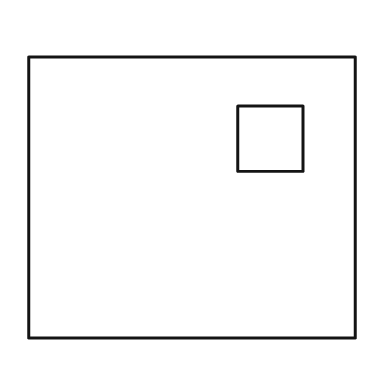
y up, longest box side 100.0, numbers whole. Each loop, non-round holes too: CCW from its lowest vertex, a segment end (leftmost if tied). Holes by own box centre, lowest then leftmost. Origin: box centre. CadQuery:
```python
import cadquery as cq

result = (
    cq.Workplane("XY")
    .moveTo(-50.0, -43.0)
    .lineTo(50.0, -43.0)
    .lineTo(50.0, 43.0)
    .lineTo(-50.0, 43.0)
    .close()
    .moveTo(14.0, 8.0)
    .lineTo(34.0, 8.0)
    .lineTo(34.0, 28.0)
    .lineTo(14.0, 28.0)
    .close()
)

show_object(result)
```